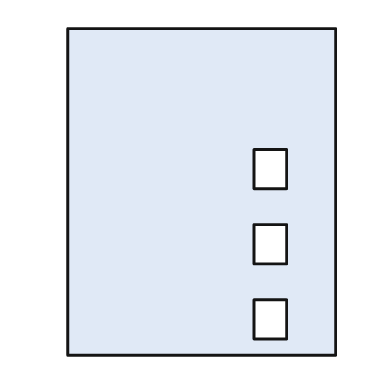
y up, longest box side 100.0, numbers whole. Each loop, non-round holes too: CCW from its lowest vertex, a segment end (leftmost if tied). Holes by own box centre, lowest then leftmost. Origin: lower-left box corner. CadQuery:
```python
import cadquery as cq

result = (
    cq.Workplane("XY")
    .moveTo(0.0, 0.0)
    .lineTo(82.0, 0.0)
    .lineTo(82.0, 100.0)
    .lineTo(0.0, 100.0)
    .close()
    .moveTo(57.0, 5.0)
    .lineTo(67.0, 5.0)
    .lineTo(67.0, 17.0)
    .lineTo(57.0, 17.0)
    .close()
    .moveTo(57.0, 28.0)
    .lineTo(67.0, 28.0)
    .lineTo(67.0, 40.0)
    .lineTo(57.0, 40.0)
    .close()
    .moveTo(57.0, 51.0)
    .lineTo(67.0, 51.0)
    .lineTo(67.0, 63.0)
    .lineTo(57.0, 63.0)
    .close()
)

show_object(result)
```